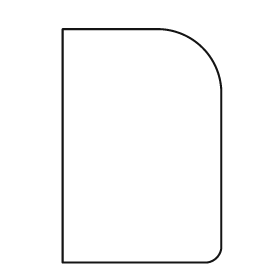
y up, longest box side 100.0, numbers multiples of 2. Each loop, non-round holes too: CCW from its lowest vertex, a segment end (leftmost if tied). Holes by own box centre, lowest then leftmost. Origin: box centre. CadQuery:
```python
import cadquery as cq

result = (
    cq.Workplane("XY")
    .moveTo(-34.0, -50.0)
    .lineTo(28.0, -50.0)
    .threePointArc((32.0, -48.0), (34.0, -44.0))
    .lineTo(34.0, 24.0)
    .threePointArc((26.0, 42.0), (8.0, 50.0))
    .lineTo(-34.0, 50.0)
    .close()
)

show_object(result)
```